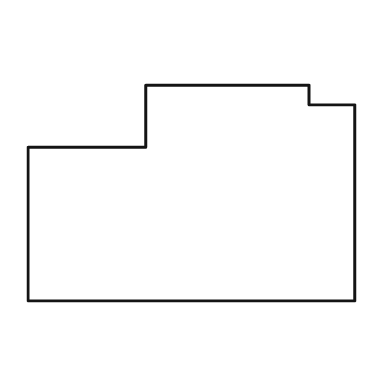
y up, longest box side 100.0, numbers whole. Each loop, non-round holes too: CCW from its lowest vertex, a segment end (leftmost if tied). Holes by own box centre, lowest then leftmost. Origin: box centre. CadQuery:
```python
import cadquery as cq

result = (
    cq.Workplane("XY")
    .moveTo(-50.0, -33.0)
    .lineTo(50.0, -33.0)
    .lineTo(50.0, 27.0)
    .lineTo(36.0, 27.0)
    .lineTo(36.0, 33.0)
    .lineTo(-14.0, 33.0)
    .lineTo(-14.0, 14.0)
    .lineTo(-50.0, 14.0)
    .close()
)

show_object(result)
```